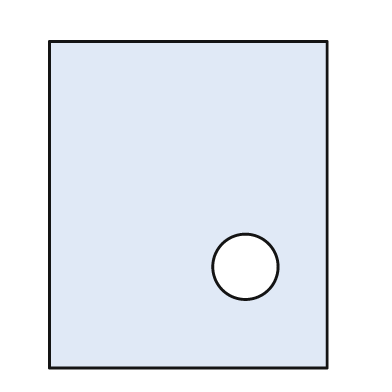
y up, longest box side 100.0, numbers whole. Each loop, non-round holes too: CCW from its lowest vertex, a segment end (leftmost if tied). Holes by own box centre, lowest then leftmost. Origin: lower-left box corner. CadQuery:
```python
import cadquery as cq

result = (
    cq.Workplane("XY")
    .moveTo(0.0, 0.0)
    .lineTo(85.0, 0.0)
    .lineTo(85.0, 100.0)
    .lineTo(0.0, 100.0)
    .close()
    .moveTo(60.0, 31.0)
    .circle(10.0)
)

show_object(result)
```